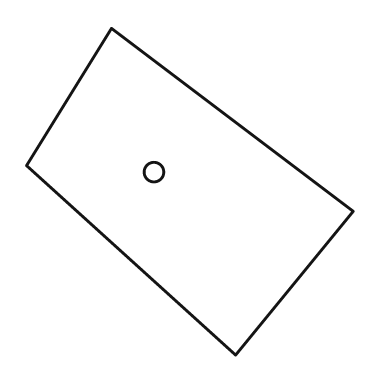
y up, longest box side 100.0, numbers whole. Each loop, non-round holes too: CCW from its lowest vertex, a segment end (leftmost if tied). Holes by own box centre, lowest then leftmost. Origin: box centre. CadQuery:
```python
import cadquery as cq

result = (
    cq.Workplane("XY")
    .moveTo(14.0, -50.0)
    .lineTo(50.0, -6.0)
    .lineTo(-24.0, 50.0)
    .lineTo(-50.0, 8.0)
    .close()
    .moveTo(-11.0, 6.0)
    .circle(3.0)
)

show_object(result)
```